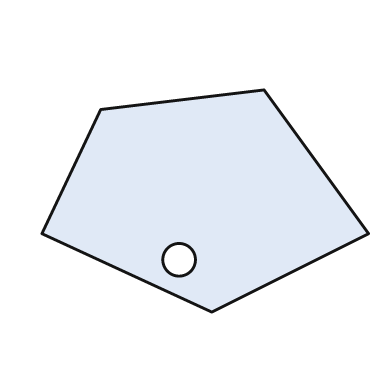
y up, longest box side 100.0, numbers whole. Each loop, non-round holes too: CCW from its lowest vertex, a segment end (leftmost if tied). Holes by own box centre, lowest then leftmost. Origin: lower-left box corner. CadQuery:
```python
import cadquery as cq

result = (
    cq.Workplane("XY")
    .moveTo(52.0, 0.0)
    .lineTo(100.0, 24.0)
    .lineTo(68.0, 68.0)
    .lineTo(18.0, 62.0)
    .lineTo(0.0, 24.0)
    .close()
    .moveTo(42.0, 16.0)
    .circle(5.0)
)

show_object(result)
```